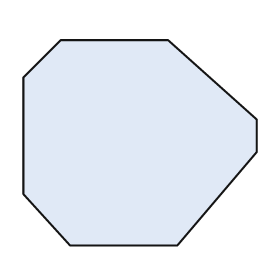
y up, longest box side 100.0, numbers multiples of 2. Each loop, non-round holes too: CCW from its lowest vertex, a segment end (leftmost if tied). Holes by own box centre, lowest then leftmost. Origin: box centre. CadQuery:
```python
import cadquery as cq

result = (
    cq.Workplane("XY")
    .moveTo(-30.0, -44.0)
    .lineTo(16.0, -44.0)
    .lineTo(50.0, -4.0)
    .lineTo(50.0, 10.0)
    .lineTo(12.0, 44.0)
    .lineTo(-34.0, 44.0)
    .lineTo(-50.0, 28.0)
    .lineTo(-50.0, -22.0)
    .close()
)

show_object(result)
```